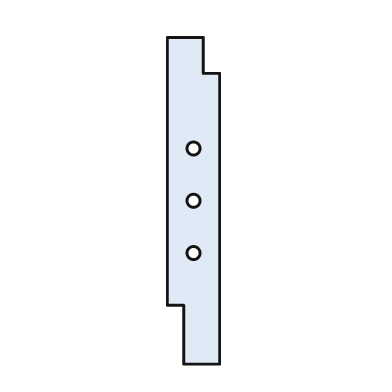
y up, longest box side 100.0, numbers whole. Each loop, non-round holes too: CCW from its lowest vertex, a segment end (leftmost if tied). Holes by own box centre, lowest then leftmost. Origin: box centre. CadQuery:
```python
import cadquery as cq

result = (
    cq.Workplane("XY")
    .moveTo(-3.0, -50.0)
    .lineTo(8.0, -50.0)
    .lineTo(8.0, 39.0)
    .lineTo(3.0, 39.0)
    .lineTo(3.0, 50.0)
    .lineTo(-8.0, 50.0)
    .lineTo(-8.0, -32.0)
    .lineTo(-3.0, -32.0)
    .close()
    .moveTo(0.0, -16.0)
    .circle(2.0)
    .moveTo(0.0, 0.0)
    .circle(2.0)
    .moveTo(0.0, 16.0)
    .circle(2.0)
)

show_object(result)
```